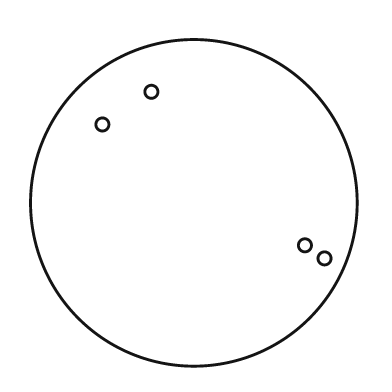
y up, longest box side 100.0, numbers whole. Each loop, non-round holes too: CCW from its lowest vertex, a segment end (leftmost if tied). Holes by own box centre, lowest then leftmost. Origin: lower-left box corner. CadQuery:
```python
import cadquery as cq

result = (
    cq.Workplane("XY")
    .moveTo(50.0, 50.0)
    .circle(50.0)
    .moveTo(90.0, 33.0)
    .circle(2.0)
    .moveTo(84.0, 37.0)
    .circle(2.0)
    .moveTo(22.0, 74.0)
    .circle(2.0)
    .moveTo(37.0, 84.0)
    .circle(2.0)
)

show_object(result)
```